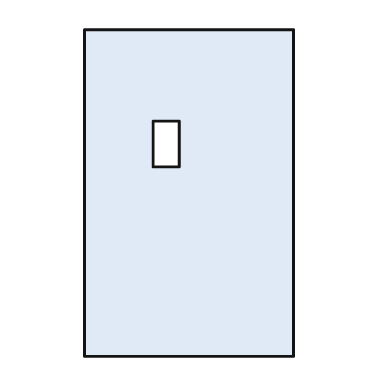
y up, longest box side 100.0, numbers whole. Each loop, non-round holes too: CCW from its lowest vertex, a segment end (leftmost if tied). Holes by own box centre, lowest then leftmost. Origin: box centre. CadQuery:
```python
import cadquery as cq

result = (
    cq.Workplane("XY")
    .moveTo(-32.0, -50.0)
    .lineTo(32.0, -50.0)
    .lineTo(32.0, 50.0)
    .lineTo(-32.0, 50.0)
    .close()
    .moveTo(-11.0, 8.0)
    .lineTo(-3.0, 8.0)
    .lineTo(-3.0, 22.0)
    .lineTo(-11.0, 22.0)
    .close()
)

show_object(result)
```